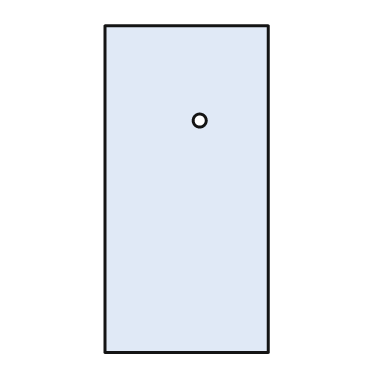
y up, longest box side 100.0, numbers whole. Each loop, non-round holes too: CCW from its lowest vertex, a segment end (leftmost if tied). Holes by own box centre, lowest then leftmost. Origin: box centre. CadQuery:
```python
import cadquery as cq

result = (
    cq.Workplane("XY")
    .moveTo(-25.0, -50.0)
    .lineTo(25.0, -50.0)
    .lineTo(25.0, 50.0)
    .lineTo(-25.0, 50.0)
    .close()
    .moveTo(4.0, 21.0)
    .circle(2.0)
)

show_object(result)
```